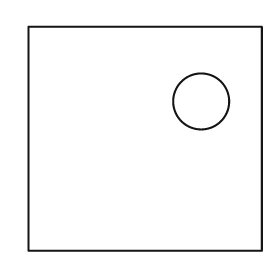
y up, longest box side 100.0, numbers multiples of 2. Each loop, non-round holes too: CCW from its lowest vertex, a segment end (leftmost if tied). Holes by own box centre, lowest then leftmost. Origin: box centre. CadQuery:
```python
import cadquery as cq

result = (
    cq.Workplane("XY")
    .moveTo(-50.0, -48.0)
    .lineTo(50.0, -48.0)
    .lineTo(50.0, 48.0)
    .lineTo(-50.0, 48.0)
    .close()
    .moveTo(24.0, 16.0)
    .circle(12.0)
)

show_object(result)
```